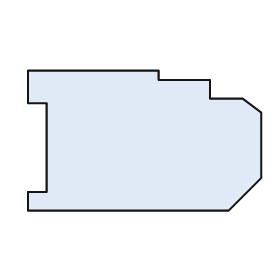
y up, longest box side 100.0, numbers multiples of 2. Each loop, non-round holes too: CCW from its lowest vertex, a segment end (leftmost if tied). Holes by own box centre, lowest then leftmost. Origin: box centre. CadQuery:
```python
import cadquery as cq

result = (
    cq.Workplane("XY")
    .moveTo(-50.0, -30.0)
    .lineTo(36.0, -30.0)
    .lineTo(50.0, -16.0)
    .lineTo(50.0, 12.0)
    .lineTo(42.0, 18.0)
    .lineTo(28.0, 18.0)
    .lineTo(28.0, 26.0)
    .lineTo(6.0, 26.0)
    .lineTo(6.0, 30.0)
    .lineTo(-50.0, 30.0)
    .lineTo(-50.0, 16.0)
    .lineTo(-42.0, 16.0)
    .lineTo(-42.0, -22.0)
    .lineTo(-50.0, -22.0)
    .close()
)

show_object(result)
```